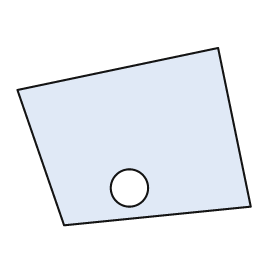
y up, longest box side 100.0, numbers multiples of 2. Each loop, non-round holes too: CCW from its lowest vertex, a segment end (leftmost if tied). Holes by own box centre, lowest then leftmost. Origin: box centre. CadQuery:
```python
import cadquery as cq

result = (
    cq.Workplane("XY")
    .moveTo(-30.0, -38.0)
    .lineTo(50.0, -30.0)
    .lineTo(36.0, 38.0)
    .lineTo(-50.0, 20.0)
    .close()
    .moveTo(-2.0, -22.0)
    .circle(8.0)
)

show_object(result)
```